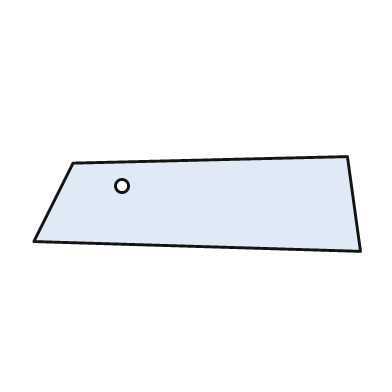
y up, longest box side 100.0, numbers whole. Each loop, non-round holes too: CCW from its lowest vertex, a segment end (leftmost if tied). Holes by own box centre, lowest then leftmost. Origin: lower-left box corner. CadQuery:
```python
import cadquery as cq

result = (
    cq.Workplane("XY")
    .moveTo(100.0, 0.0)
    .lineTo(96.0, 29.0)
    .lineTo(12.0, 27.0)
    .lineTo(0.0, 3.0)
    .close()
    .moveTo(27.0, 20.0)
    .circle(2.0)
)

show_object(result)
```